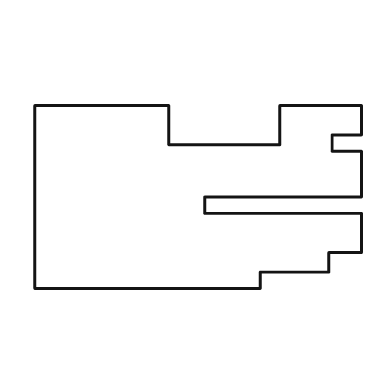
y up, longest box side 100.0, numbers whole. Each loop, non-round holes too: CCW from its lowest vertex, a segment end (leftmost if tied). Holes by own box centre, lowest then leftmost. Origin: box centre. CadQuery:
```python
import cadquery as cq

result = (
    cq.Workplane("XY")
    .moveTo(-50.0, -28.0)
    .lineTo(19.0, -28.0)
    .lineTo(19.0, -23.0)
    .lineTo(40.0, -23.0)
    .lineTo(40.0, -17.0)
    .lineTo(50.0, -17.0)
    .lineTo(50.0, -5.0)
    .lineTo(2.0, -5.0)
    .lineTo(2.0, 0.0)
    .lineTo(50.0, 0.0)
    .lineTo(50.0, 14.0)
    .lineTo(41.0, 14.0)
    .lineTo(41.0, 19.0)
    .lineTo(50.0, 19.0)
    .lineTo(50.0, 28.0)
    .lineTo(25.0, 28.0)
    .lineTo(25.0, 16.0)
    .lineTo(-9.0, 16.0)
    .lineTo(-9.0, 28.0)
    .lineTo(-50.0, 28.0)
    .close()
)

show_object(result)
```